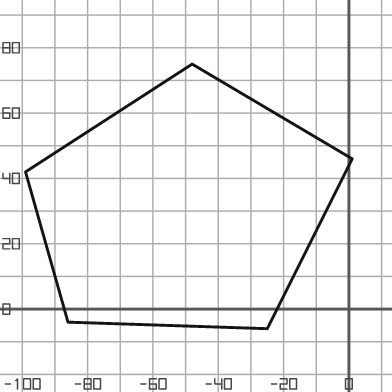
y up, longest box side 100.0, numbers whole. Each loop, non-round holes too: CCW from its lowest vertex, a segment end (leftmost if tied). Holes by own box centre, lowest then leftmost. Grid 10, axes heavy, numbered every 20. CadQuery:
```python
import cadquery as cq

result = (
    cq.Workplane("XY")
    .moveTo(-25.0, -6.0)
    .lineTo(1.0, 46.0)
    .lineTo(-48.0, 75.0)
    .lineTo(-99.0, 42.0)
    .lineTo(-86.0, -4.0)
    .close()
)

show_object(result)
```